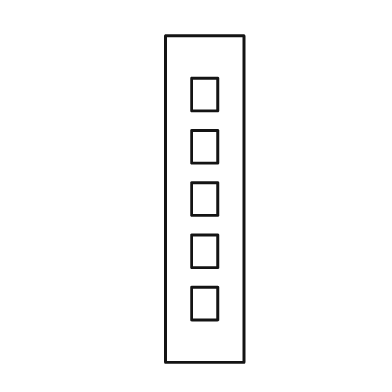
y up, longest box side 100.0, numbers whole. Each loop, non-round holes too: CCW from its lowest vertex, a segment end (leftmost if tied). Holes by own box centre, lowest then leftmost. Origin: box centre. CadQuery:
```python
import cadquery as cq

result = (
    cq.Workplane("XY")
    .moveTo(-12.0, -50.0)
    .lineTo(12.0, -50.0)
    .lineTo(12.0, 50.0)
    .lineTo(-12.0, 50.0)
    .close()
    .moveTo(-4.0, -37.0)
    .lineTo(4.0, -37.0)
    .lineTo(4.0, -27.0)
    .lineTo(-4.0, -27.0)
    .close()
    .moveTo(-4.0, -21.0)
    .lineTo(4.0, -21.0)
    .lineTo(4.0, -11.0)
    .lineTo(-4.0, -11.0)
    .close()
    .moveTo(-4.0, -5.0)
    .lineTo(4.0, -5.0)
    .lineTo(4.0, 5.0)
    .lineTo(-4.0, 5.0)
    .close()
    .moveTo(-4.0, 11.0)
    .lineTo(4.0, 11.0)
    .lineTo(4.0, 21.0)
    .lineTo(-4.0, 21.0)
    .close()
    .moveTo(-4.0, 27.0)
    .lineTo(4.0, 27.0)
    .lineTo(4.0, 37.0)
    .lineTo(-4.0, 37.0)
    .close()
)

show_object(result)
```